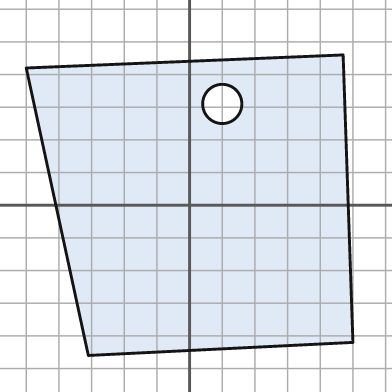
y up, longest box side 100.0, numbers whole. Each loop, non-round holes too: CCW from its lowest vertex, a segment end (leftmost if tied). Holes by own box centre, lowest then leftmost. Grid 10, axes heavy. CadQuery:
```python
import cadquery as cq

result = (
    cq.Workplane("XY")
    .moveTo(-31.0, -46.0)
    .lineTo(50.0, -42.0)
    .lineTo(47.0, 46.0)
    .lineTo(-50.0, 42.0)
    .close()
    .moveTo(10.0, 31.0)
    .circle(6.0)
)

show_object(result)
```